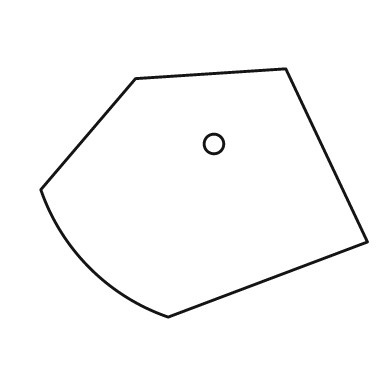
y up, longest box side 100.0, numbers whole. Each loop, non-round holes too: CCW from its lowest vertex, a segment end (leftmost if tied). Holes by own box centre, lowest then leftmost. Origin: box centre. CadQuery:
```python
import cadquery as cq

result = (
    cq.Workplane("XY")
    .moveTo(-11.0, -38.0)
    .lineTo(50.0, -15.0)
    .lineTo(25.0, 38.0)
    .lineTo(-21.0, 35.0)
    .lineTo(-50.0, 1.0)
    .threePointArc((-35.0, -23.0), (-11.0, -38.0))
    .close()
    .moveTo(3.0, 15.0)
    .circle(3.0)
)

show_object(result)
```